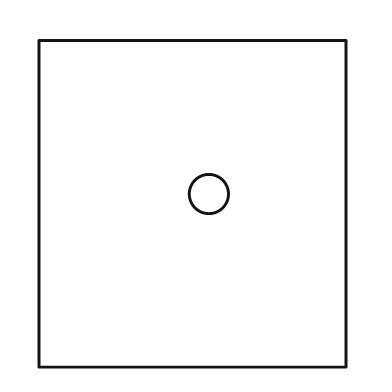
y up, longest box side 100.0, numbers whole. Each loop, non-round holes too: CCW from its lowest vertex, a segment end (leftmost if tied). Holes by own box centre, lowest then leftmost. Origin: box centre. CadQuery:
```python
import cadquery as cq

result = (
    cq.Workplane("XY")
    .moveTo(-47.0, -50.0)
    .lineTo(47.0, -50.0)
    .lineTo(47.0, 50.0)
    .lineTo(-47.0, 50.0)
    .close()
    .moveTo(5.0, 3.0)
    .circle(6.0)
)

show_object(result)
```